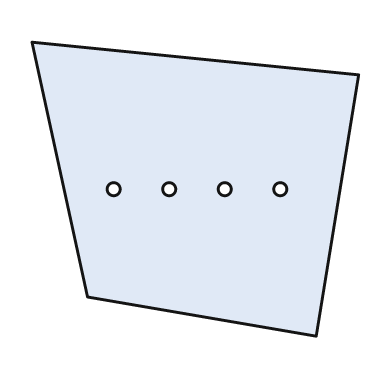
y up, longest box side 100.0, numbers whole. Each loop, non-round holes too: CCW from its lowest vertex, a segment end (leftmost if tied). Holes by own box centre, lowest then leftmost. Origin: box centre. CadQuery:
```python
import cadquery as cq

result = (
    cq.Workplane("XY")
    .moveTo(37.0, -45.0)
    .lineTo(50.0, 35.0)
    .lineTo(-50.0, 45.0)
    .lineTo(-33.0, -33.0)
    .close()
    .moveTo(-25.0, 0.0)
    .circle(2.0)
    .moveTo(-8.0, 0.0)
    .circle(2.0)
    .moveTo(9.0, 0.0)
    .circle(2.0)
    .moveTo(26.0, 0.0)
    .circle(2.0)
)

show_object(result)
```